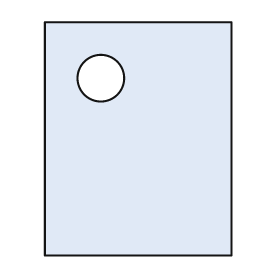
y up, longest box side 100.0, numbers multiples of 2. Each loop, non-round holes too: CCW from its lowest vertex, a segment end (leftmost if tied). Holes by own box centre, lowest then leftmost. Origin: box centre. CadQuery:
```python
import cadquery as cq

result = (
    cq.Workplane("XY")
    .moveTo(-40.0, -50.0)
    .lineTo(40.0, -50.0)
    .lineTo(40.0, 50.0)
    .lineTo(-40.0, 50.0)
    .close()
    .moveTo(-16.0, 26.0)
    .circle(10.0)
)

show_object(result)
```